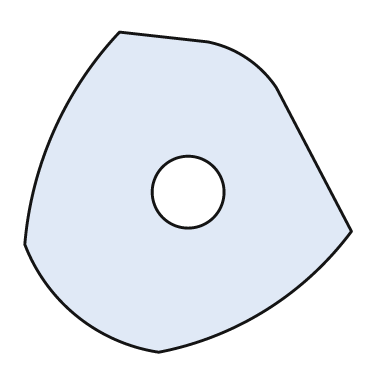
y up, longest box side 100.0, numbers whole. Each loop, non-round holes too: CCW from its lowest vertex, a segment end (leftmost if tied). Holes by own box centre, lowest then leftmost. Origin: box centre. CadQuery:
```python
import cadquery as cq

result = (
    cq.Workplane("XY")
    .moveTo(-9.0, -49.0)
    .threePointArc((24.0, -36.0), (50.0, -12.0))
    .lineTo(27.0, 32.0)
    .threePointArc((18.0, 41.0), (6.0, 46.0))
    .lineTo(-21.0, 49.0)
    .threePointArc((-41.0, 19.0), (-50.0, -16.0))
    .threePointArc((-34.0, -38.0), (-9.0, -49.0))
    .close()
    .moveTo(0.0, 0.0)
    .circle(11.0)
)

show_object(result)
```